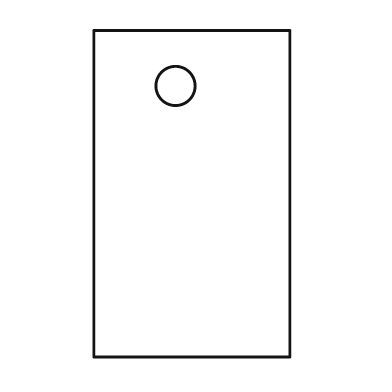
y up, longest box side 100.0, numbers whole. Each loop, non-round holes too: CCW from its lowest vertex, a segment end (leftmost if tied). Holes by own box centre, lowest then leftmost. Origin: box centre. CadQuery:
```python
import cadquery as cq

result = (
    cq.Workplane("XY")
    .moveTo(-30.0, -50.0)
    .lineTo(30.0, -50.0)
    .lineTo(30.0, 50.0)
    .lineTo(-30.0, 50.0)
    .close()
    .moveTo(-5.0, 33.0)
    .circle(6.0)
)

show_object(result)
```